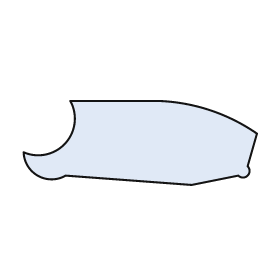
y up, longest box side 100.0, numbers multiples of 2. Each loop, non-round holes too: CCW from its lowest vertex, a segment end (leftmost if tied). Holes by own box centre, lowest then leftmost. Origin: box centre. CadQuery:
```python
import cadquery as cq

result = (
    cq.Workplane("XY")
    .moveTo(22.0, -18.0)
    .lineTo(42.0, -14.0)
    .threePointArc((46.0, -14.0), (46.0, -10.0))
    .lineTo(50.0, 4.0)
    .threePointArc((30.0, 14.0), (8.0, 18.0))
    .lineTo(-30.0, 18.0)
    .threePointArc((-32.0, 0.0), (-50.0, -4.0))
    .threePointArc((-44.0, -14.0), (-32.0, -14.0))
    .close()
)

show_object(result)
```